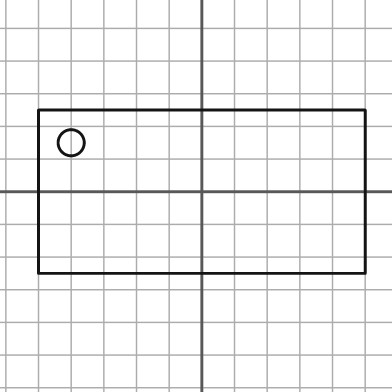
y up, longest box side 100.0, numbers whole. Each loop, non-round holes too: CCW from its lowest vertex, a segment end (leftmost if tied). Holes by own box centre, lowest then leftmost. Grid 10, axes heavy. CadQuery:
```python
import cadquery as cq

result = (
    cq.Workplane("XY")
    .moveTo(-50.0, -25.0)
    .lineTo(50.0, -25.0)
    .lineTo(50.0, 25.0)
    .lineTo(-50.0, 25.0)
    .close()
    .moveTo(-40.0, 15.0)
    .circle(4.0)
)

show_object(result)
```